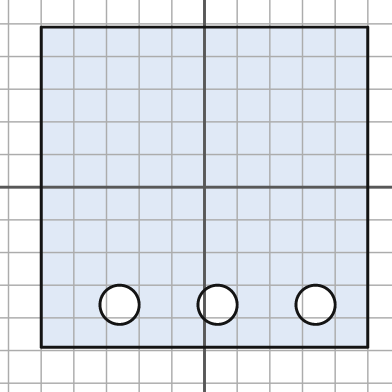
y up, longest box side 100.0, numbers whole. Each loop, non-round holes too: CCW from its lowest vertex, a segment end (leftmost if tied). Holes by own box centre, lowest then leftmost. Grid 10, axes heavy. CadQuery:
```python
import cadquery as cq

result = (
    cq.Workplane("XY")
    .moveTo(-50.0, -49.0)
    .lineTo(50.0, -49.0)
    .lineTo(50.0, 49.0)
    .lineTo(-50.0, 49.0)
    .close()
    .moveTo(-26.0, -36.0)
    .circle(6.0)
    .moveTo(4.0, -36.0)
    .circle(6.0)
    .moveTo(34.0, -36.0)
    .circle(6.0)
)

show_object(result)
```